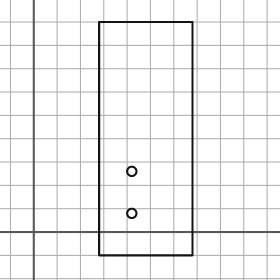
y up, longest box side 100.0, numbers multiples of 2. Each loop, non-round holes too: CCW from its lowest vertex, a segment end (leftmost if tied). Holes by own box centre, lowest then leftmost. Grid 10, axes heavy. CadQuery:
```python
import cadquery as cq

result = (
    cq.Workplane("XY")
    .moveTo(28.0, -10.0)
    .lineTo(68.0, -10.0)
    .lineTo(68.0, 90.0)
    .lineTo(28.0, 90.0)
    .close()
    .moveTo(42.0, 8.0)
    .circle(2.0)
    .moveTo(42.0, 26.0)
    .circle(2.0)
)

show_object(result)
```